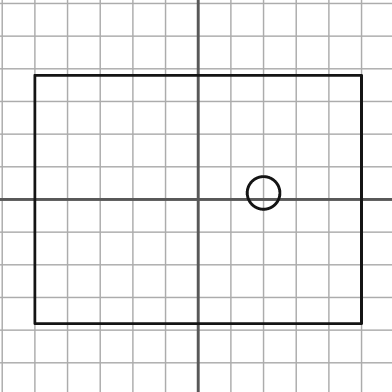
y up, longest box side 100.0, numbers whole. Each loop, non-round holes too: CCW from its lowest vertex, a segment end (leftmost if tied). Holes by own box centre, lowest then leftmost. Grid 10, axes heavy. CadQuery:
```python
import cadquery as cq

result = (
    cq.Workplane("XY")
    .moveTo(-50.0, -38.0)
    .lineTo(50.0, -38.0)
    .lineTo(50.0, 38.0)
    .lineTo(-50.0, 38.0)
    .close()
    .moveTo(20.0, 2.0)
    .circle(5.0)
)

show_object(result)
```